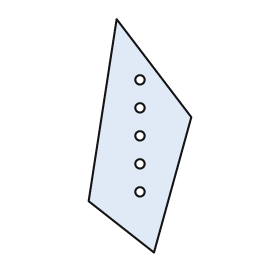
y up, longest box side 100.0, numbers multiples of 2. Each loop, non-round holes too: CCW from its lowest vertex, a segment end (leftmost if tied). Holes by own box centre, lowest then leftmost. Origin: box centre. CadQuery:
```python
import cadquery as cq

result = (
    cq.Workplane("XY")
    .moveTo(6.0, -50.0)
    .lineTo(22.0, 8.0)
    .lineTo(-10.0, 50.0)
    .lineTo(-22.0, -28.0)
    .close()
    .moveTo(0.0, -24.0)
    .circle(2.0)
    .moveTo(0.0, -12.0)
    .circle(2.0)
    .moveTo(0.0, 0.0)
    .circle(2.0)
    .moveTo(0.0, 12.0)
    .circle(2.0)
    .moveTo(0.0, 24.0)
    .circle(2.0)
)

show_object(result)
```